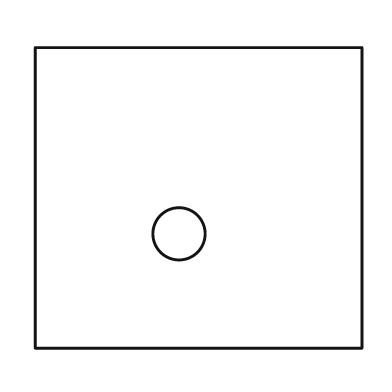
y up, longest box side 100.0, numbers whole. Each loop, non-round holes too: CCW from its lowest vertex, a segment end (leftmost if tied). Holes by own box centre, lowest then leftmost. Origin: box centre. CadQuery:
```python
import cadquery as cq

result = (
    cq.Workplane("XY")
    .moveTo(-50.0, -46.0)
    .lineTo(50.0, -46.0)
    .lineTo(50.0, 46.0)
    .lineTo(-50.0, 46.0)
    .close()
    .moveTo(-6.0, -11.0)
    .circle(8.0)
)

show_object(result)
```